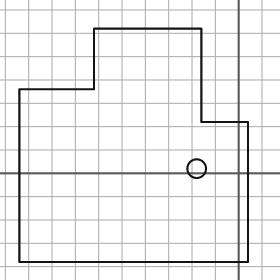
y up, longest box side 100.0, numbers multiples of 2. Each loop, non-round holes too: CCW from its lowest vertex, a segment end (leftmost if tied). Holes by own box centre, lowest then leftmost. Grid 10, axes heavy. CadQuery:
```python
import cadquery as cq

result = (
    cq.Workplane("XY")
    .moveTo(-94.0, -38.0)
    .lineTo(4.0, -38.0)
    .lineTo(4.0, 22.0)
    .lineTo(-16.0, 22.0)
    .lineTo(-16.0, 62.0)
    .lineTo(-62.0, 62.0)
    .lineTo(-62.0, 36.0)
    .lineTo(-94.0, 36.0)
    .close()
    .moveTo(-18.0, 2.0)
    .circle(4.0)
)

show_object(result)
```